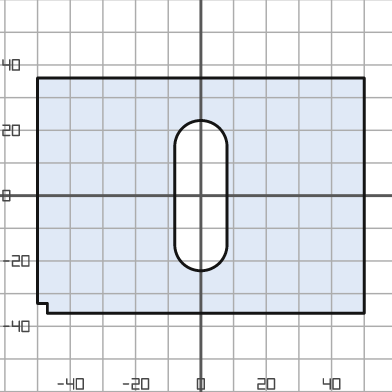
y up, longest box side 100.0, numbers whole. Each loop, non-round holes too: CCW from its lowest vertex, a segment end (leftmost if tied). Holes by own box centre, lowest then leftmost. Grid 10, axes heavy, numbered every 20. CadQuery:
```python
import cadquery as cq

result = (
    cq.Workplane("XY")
    .moveTo(-47.0, -36.0)
    .lineTo(50.0, -36.0)
    .lineTo(50.0, 36.0)
    .lineTo(-50.0, 36.0)
    .lineTo(-50.0, -33.0)
    .lineTo(-47.0, -33.0)
    .close()
    .moveTo(-8.0, -15.0)
    .threePointArc((0.0, -23.0), (8.0, -15.0))
    .lineTo(8.0, 15.0)
    .threePointArc((0.0, 23.0), (-8.0, 15.0))
    .close()
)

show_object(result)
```